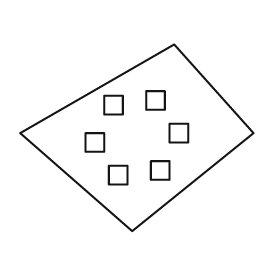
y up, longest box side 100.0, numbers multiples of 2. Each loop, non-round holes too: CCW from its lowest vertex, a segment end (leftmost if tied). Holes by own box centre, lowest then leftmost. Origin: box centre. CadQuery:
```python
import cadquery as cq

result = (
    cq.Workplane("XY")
    .moveTo(-2.0, -40.0)
    .lineTo(50.0, 2.0)
    .lineTo(16.0, 40.0)
    .lineTo(-50.0, 2.0)
    .close()
    .moveTo(-12.0, -20.0)
    .lineTo(-4.0, -20.0)
    .lineTo(-4.0, -12.0)
    .lineTo(-12.0, -12.0)
    .close()
    .moveTo(6.0, -18.0)
    .lineTo(14.0, -18.0)
    .lineTo(14.0, -10.0)
    .lineTo(6.0, -10.0)
    .close()
    .moveTo(-22.0, -6.0)
    .lineTo(-14.0, -6.0)
    .lineTo(-14.0, 2.0)
    .lineTo(-22.0, 2.0)
    .close()
    .moveTo(14.0, -2.0)
    .lineTo(22.0, -2.0)
    .lineTo(22.0, 6.0)
    .lineTo(14.0, 6.0)
    .close()
    .moveTo(-14.0, 10.0)
    .lineTo(-6.0, 10.0)
    .lineTo(-6.0, 18.0)
    .lineTo(-14.0, 18.0)
    .close()
    .moveTo(4.0, 12.0)
    .lineTo(12.0, 12.0)
    .lineTo(12.0, 20.0)
    .lineTo(4.0, 20.0)
    .close()
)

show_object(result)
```